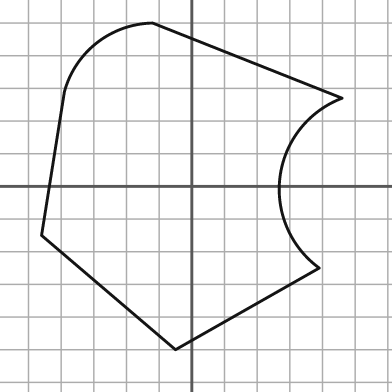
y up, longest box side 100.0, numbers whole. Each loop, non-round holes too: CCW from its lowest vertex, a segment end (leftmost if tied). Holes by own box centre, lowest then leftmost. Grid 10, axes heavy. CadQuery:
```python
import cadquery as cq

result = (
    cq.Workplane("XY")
    .moveTo(-5.0, -50.0)
    .lineTo(39.0, -25.0)
    .threePointArc((27.0, 3.0), (46.0, 27.0))
    .lineTo(-12.0, 50.0)
    .threePointArc((-29.0, 44.0), (-39.0, 29.0))
    .lineTo(-46.0, -15.0)
    .close()
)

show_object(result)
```